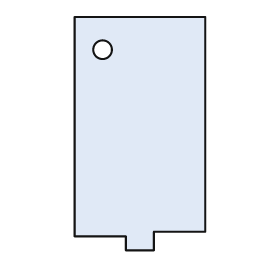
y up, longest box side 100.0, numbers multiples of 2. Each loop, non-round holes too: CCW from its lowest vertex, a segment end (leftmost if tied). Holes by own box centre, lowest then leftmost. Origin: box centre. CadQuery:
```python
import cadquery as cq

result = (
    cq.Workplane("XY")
    .moveTo(-6.0, -50.0)
    .lineTo(6.0, -50.0)
    .lineTo(6.0, -42.0)
    .lineTo(28.0, -42.0)
    .lineTo(28.0, 50.0)
    .lineTo(-28.0, 50.0)
    .lineTo(-28.0, -44.0)
    .lineTo(-6.0, -44.0)
    .close()
    .moveTo(-16.0, 36.0)
    .circle(4.0)
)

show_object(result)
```